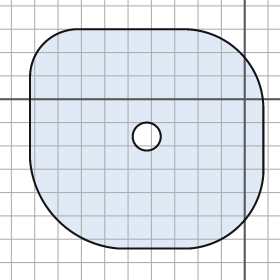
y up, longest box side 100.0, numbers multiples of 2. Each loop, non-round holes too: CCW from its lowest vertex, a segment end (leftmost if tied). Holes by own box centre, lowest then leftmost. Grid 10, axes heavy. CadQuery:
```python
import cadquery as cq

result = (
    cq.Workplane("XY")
    .moveTo(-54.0, -64.0)
    .lineTo(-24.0, -64.0)
    .threePointArc((-2.0, -54.0), (8.0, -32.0))
    .lineTo(8.0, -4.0)
    .threePointArc((-2.0, 20.0), (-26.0, 30.0))
    .lineTo(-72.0, 30.0)
    .threePointArc((-86.0, 24.0), (-92.0, 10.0))
    .lineTo(-92.0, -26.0)
    .threePointArc((-80.0, -52.0), (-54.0, -64.0))
    .close()
    .moveTo(-42.0, -16.0)
    .circle(6.0)
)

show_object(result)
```